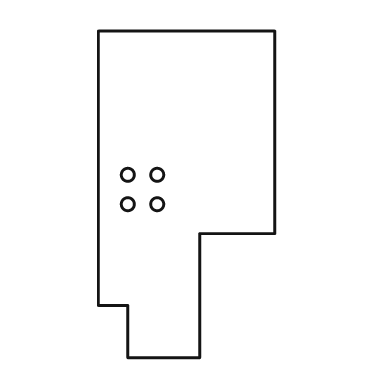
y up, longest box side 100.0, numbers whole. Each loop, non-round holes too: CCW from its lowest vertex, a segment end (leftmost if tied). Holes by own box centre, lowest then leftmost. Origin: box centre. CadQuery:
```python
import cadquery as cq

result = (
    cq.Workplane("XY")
    .moveTo(-18.0, -50.0)
    .lineTo(4.0, -50.0)
    .lineTo(4.0, -12.0)
    .lineTo(27.0, -12.0)
    .lineTo(27.0, 50.0)
    .lineTo(-27.0, 50.0)
    .lineTo(-27.0, -34.0)
    .lineTo(-18.0, -34.0)
    .close()
    .moveTo(-18.0, -3.0)
    .circle(2.0)
    .moveTo(-9.0, -3.0)
    .circle(2.0)
    .moveTo(-18.0, 6.0)
    .circle(2.0)
    .moveTo(-9.0, 6.0)
    .circle(2.0)
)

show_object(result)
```